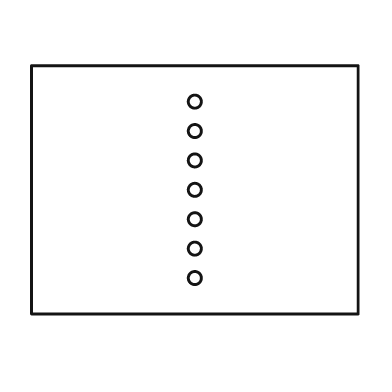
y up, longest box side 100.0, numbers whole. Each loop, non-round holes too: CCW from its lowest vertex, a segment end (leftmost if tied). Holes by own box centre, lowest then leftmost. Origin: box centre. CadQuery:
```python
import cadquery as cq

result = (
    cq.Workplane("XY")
    .moveTo(-50.0, -38.0)
    .lineTo(50.0, -38.0)
    .lineTo(50.0, 38.0)
    .lineTo(-50.0, 38.0)
    .close()
    .moveTo(0.0, -27.0)
    .circle(2.0)
    .moveTo(0.0, -18.0)
    .circle(2.0)
    .moveTo(0.0, -9.0)
    .circle(2.0)
    .moveTo(0.0, 0.0)
    .circle(2.0)
    .moveTo(0.0, 9.0)
    .circle(2.0)
    .moveTo(0.0, 18.0)
    .circle(2.0)
    .moveTo(0.0, 27.0)
    .circle(2.0)
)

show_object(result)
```